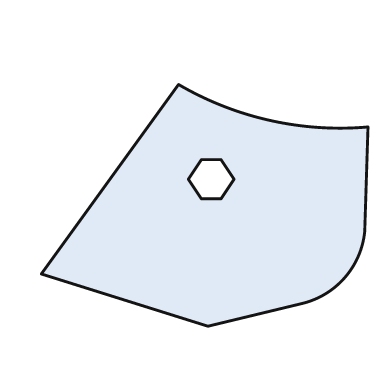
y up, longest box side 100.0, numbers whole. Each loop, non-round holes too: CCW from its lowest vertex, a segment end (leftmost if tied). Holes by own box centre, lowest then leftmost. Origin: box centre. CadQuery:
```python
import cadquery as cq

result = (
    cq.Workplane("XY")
    .moveTo(1.0, -37.0)
    .lineTo(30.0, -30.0)
    .threePointArc((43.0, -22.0), (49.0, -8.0))
    .lineTo(50.0, 24.0)
    .threePointArc((20.0, 26.0), (-8.0, 37.0))
    .lineTo(-50.0, -21.0)
    .close()
    .moveTo(-1.0, 2.0)
    .lineTo(5.0, 2.0)
    .lineTo(9.0, 8.0)
    .lineTo(5.0, 14.0)
    .lineTo(-1.0, 14.0)
    .lineTo(-5.0, 8.0)
    .close()
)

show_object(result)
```